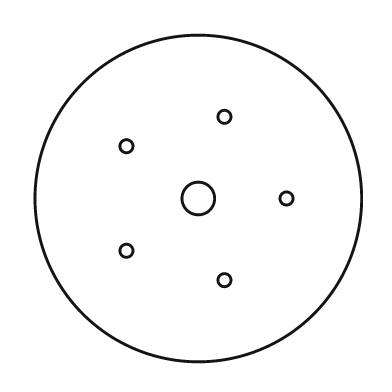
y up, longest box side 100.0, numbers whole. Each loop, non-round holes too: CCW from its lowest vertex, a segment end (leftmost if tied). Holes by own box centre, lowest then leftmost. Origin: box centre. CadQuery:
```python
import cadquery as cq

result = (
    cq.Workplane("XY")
    .moveTo(0.0, 0.0)
    .circle(50.0)
    .moveTo(8.0, -25.0)
    .circle(2.0)
    .moveTo(-22.0, -16.0)
    .circle(2.0)
    .moveTo(0.0, 0.0)
    .circle(5.0)
    .moveTo(27.0, 0.0)
    .circle(2.0)
    .moveTo(-22.0, 16.0)
    .circle(2.0)
    .moveTo(8.0, 25.0)
    .circle(2.0)
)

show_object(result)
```